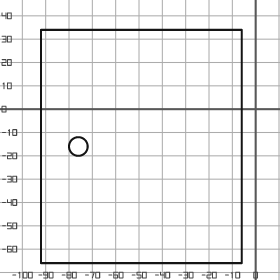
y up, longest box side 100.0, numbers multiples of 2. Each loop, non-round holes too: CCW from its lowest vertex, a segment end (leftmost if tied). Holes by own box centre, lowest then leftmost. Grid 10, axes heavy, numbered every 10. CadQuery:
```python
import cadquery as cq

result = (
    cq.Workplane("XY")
    .moveTo(-92.0, -66.0)
    .lineTo(-6.0, -66.0)
    .lineTo(-6.0, 34.0)
    .lineTo(-92.0, 34.0)
    .close()
    .moveTo(-76.0, -16.0)
    .circle(4.0)
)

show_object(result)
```